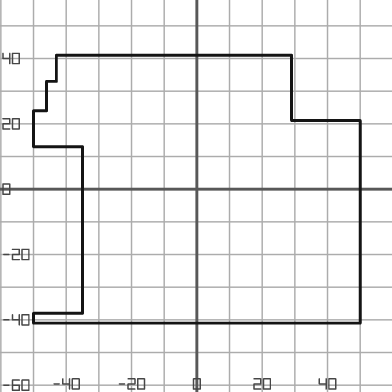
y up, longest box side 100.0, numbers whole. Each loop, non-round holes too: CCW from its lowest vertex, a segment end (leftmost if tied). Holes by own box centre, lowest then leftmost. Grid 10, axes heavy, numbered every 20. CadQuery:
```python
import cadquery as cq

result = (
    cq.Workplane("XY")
    .moveTo(-50.0, -41.0)
    .lineTo(50.0, -41.0)
    .lineTo(50.0, 21.0)
    .lineTo(29.0, 21.0)
    .lineTo(29.0, 41.0)
    .lineTo(-43.0, 41.0)
    .lineTo(-43.0, 33.0)
    .lineTo(-46.0, 33.0)
    .lineTo(-46.0, 24.0)
    .lineTo(-50.0, 24.0)
    .lineTo(-50.0, 13.0)
    .lineTo(-35.0, 13.0)
    .lineTo(-35.0, -38.0)
    .lineTo(-50.0, -38.0)
    .close()
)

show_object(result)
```